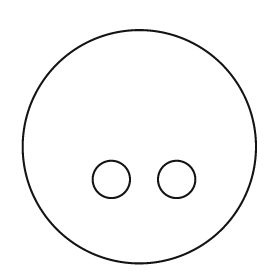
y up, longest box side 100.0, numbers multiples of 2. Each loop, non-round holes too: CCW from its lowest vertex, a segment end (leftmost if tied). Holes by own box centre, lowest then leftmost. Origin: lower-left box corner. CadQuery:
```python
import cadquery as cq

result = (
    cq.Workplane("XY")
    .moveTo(50.0, 50.0)
    .circle(50.0)
    .moveTo(38.0, 36.0)
    .circle(8.0)
    .moveTo(66.0, 36.0)
    .circle(8.0)
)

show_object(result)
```